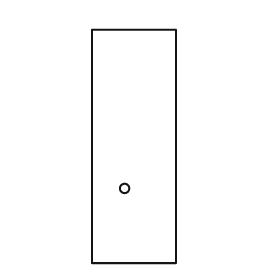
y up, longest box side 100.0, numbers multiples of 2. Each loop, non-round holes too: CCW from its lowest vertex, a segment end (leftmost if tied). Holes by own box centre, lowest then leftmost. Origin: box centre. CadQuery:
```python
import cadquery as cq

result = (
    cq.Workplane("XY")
    .moveTo(-18.0, -50.0)
    .lineTo(18.0, -50.0)
    .lineTo(18.0, 50.0)
    .lineTo(-18.0, 50.0)
    .close()
    .moveTo(-4.0, -18.0)
    .circle(2.0)
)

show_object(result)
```